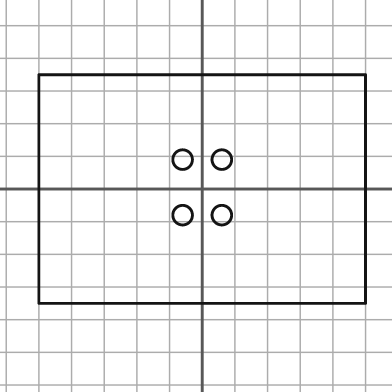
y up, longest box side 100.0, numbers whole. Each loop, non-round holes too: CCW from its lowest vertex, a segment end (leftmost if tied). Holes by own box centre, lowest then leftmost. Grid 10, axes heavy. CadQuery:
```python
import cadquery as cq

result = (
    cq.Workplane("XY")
    .moveTo(-50.0, -35.0)
    .lineTo(50.0, -35.0)
    .lineTo(50.0, 35.0)
    .lineTo(-50.0, 35.0)
    .close()
    .moveTo(-6.0, -8.0)
    .circle(3.0)
    .moveTo(6.0, -8.0)
    .circle(3.0)
    .moveTo(-6.0, 9.0)
    .circle(3.0)
    .moveTo(6.0, 9.0)
    .circle(3.0)
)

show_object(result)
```